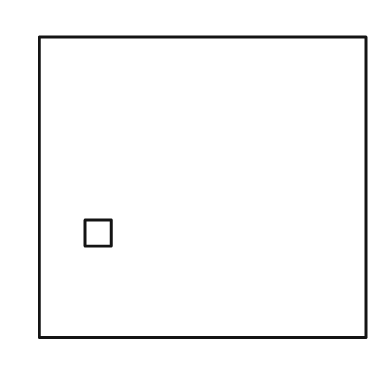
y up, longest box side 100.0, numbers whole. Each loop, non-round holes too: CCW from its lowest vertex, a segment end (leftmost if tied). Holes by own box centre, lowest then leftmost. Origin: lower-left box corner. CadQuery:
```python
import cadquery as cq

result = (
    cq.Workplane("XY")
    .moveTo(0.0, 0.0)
    .lineTo(100.0, 0.0)
    .lineTo(100.0, 92.0)
    .lineTo(0.0, 92.0)
    .close()
    .moveTo(14.0, 28.0)
    .lineTo(22.0, 28.0)
    .lineTo(22.0, 36.0)
    .lineTo(14.0, 36.0)
    .close()
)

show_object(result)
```